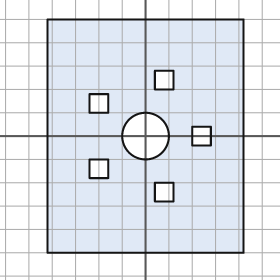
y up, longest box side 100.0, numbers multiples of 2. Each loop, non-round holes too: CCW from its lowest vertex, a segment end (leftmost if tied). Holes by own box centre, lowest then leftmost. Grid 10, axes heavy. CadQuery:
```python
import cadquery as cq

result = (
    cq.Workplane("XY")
    .moveTo(-42.0, -50.0)
    .lineTo(42.0, -50.0)
    .lineTo(42.0, 50.0)
    .lineTo(-42.0, 50.0)
    .close()
    .moveTo(4.0, -28.0)
    .lineTo(12.0, -28.0)
    .lineTo(12.0, -20.0)
    .lineTo(4.0, -20.0)
    .close()
    .moveTo(-24.0, -18.0)
    .lineTo(-16.0, -18.0)
    .lineTo(-16.0, -10.0)
    .lineTo(-24.0, -10.0)
    .close()
    .moveTo(0.0, 0.0)
    .circle(10.0)
    .moveTo(20.0, -4.0)
    .lineTo(28.0, -4.0)
    .lineTo(28.0, 4.0)
    .lineTo(20.0, 4.0)
    .close()
    .moveTo(-24.0, 10.0)
    .lineTo(-16.0, 10.0)
    .lineTo(-16.0, 18.0)
    .lineTo(-24.0, 18.0)
    .close()
    .moveTo(4.0, 20.0)
    .lineTo(12.0, 20.0)
    .lineTo(12.0, 28.0)
    .lineTo(4.0, 28.0)
    .close()
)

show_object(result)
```